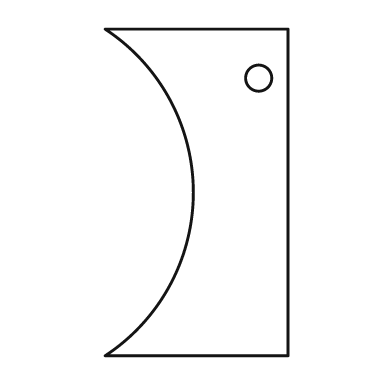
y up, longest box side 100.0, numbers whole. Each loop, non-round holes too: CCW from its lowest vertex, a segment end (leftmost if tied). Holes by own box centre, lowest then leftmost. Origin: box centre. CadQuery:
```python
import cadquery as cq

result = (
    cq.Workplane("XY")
    .moveTo(-28.0, -50.0)
    .lineTo(28.0, -50.0)
    .lineTo(28.0, 50.0)
    .lineTo(-28.0, 50.0)
    .threePointArc((-1.0, 0.0), (-28.0, -50.0))
    .close()
    .moveTo(19.0, 35.0)
    .circle(4.0)
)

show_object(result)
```